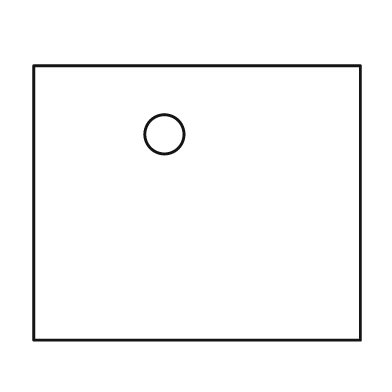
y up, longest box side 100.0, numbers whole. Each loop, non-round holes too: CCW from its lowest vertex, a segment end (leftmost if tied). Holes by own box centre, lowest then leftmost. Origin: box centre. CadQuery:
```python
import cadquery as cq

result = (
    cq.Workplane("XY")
    .moveTo(-50.0, -42.0)
    .lineTo(50.0, -42.0)
    .lineTo(50.0, 42.0)
    .lineTo(-50.0, 42.0)
    .close()
    .moveTo(-10.0, 21.0)
    .circle(6.0)
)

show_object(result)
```